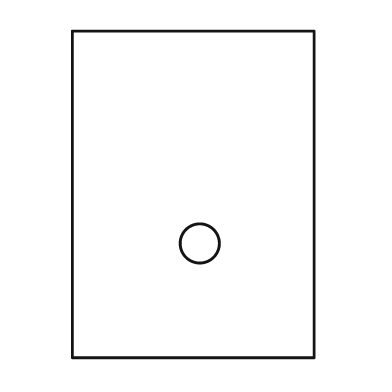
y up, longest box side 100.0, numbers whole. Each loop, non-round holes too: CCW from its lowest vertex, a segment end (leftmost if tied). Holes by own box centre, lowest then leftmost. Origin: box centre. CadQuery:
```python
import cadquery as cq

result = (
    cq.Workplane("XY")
    .moveTo(-37.0, -50.0)
    .lineTo(37.0, -50.0)
    .lineTo(37.0, 50.0)
    .lineTo(-37.0, 50.0)
    .close()
    .moveTo(2.0, -15.0)
    .circle(6.0)
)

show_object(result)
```